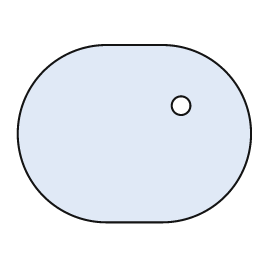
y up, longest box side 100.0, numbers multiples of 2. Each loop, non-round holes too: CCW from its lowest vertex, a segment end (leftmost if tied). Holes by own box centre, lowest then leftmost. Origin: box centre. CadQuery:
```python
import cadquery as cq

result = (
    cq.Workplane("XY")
    .moveTo(-12.0, -38.0)
    .lineTo(12.0, -38.0)
    .threePointArc((50.0, 0.0), (12.0, 38.0))
    .lineTo(-12.0, 38.0)
    .threePointArc((-50.0, 0.0), (-12.0, -38.0))
    .close()
    .moveTo(20.0, 12.0)
    .circle(4.0)
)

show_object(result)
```